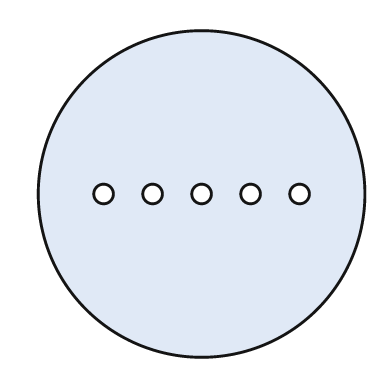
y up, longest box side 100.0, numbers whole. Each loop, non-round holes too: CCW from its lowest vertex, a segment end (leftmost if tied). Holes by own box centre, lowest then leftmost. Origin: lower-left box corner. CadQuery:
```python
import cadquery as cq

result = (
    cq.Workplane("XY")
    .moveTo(50.0, 50.0)
    .circle(50.0)
    .moveTo(20.0, 50.0)
    .circle(3.0)
    .moveTo(35.0, 50.0)
    .circle(3.0)
    .moveTo(50.0, 50.0)
    .circle(3.0)
    .moveTo(65.0, 50.0)
    .circle(3.0)
    .moveTo(80.0, 50.0)
    .circle(3.0)
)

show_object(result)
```